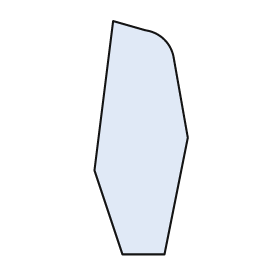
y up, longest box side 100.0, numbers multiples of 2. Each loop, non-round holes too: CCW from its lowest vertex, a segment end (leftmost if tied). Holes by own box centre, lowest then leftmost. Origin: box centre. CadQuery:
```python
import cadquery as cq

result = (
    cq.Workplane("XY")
    .moveTo(-8.0, -50.0)
    .lineTo(10.0, -50.0)
    .lineTo(20.0, 0.0)
    .lineTo(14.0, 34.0)
    .threePointArc((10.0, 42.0), (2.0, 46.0))
    .lineTo(-12.0, 50.0)
    .lineTo(-20.0, -14.0)
    .close()
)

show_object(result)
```